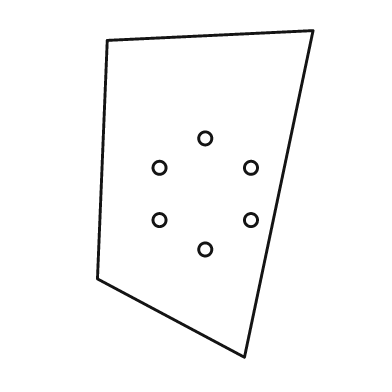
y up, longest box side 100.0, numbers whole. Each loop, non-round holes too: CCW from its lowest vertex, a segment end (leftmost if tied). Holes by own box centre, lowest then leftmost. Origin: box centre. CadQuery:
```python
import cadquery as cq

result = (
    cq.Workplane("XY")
    .moveTo(12.0, -50.0)
    .lineTo(33.0, 50.0)
    .lineTo(-30.0, 47.0)
    .lineTo(-33.0, -26.0)
    .close()
    .moveTo(0.0, -17.0)
    .circle(2.0)
    .moveTo(-14.0, -8.0)
    .circle(2.0)
    .moveTo(14.0, -8.0)
    .circle(2.0)
    .moveTo(-14.0, 8.0)
    .circle(2.0)
    .moveTo(14.0, 8.0)
    .circle(2.0)
    .moveTo(0.0, 17.0)
    .circle(2.0)
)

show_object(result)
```